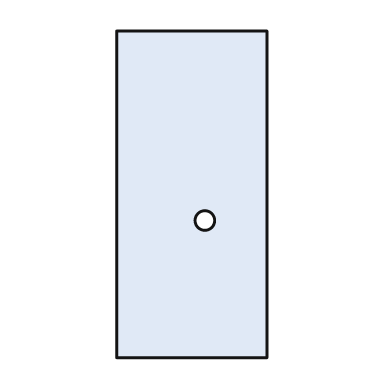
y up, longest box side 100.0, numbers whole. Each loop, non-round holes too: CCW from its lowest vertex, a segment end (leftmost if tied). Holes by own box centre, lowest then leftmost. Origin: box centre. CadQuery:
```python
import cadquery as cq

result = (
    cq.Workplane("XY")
    .moveTo(-23.0, -50.0)
    .lineTo(23.0, -50.0)
    .lineTo(23.0, 50.0)
    .lineTo(-23.0, 50.0)
    .close()
    .moveTo(4.0, -8.0)
    .circle(3.0)
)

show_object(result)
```